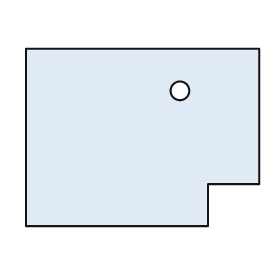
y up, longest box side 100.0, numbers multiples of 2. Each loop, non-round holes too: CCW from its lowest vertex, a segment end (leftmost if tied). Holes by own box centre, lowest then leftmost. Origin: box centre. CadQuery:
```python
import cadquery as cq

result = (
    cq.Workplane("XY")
    .moveTo(-50.0, -38.0)
    .lineTo(28.0, -38.0)
    .lineTo(28.0, -20.0)
    .lineTo(50.0, -20.0)
    .lineTo(50.0, 38.0)
    .lineTo(-50.0, 38.0)
    .close()
    .moveTo(16.0, 20.0)
    .circle(4.0)
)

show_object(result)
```